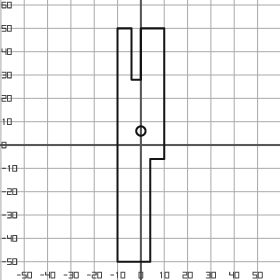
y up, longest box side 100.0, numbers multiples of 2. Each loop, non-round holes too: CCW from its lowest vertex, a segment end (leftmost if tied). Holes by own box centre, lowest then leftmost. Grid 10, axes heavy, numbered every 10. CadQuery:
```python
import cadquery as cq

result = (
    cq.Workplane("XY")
    .moveTo(-10.0, -50.0)
    .lineTo(4.0, -50.0)
    .lineTo(4.0, -6.0)
    .lineTo(10.0, -6.0)
    .lineTo(10.0, 50.0)
    .lineTo(0.0, 50.0)
    .lineTo(0.0, 28.0)
    .lineTo(-4.0, 28.0)
    .lineTo(-4.0, 50.0)
    .lineTo(-10.0, 50.0)
    .close()
    .moveTo(0.0, 6.0)
    .circle(2.0)
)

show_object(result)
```